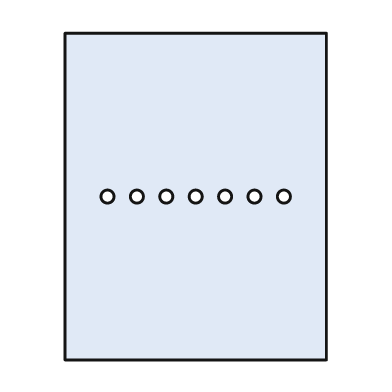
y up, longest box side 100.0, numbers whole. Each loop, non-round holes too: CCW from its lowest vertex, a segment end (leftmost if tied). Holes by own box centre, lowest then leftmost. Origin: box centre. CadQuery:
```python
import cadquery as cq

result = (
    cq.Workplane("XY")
    .moveTo(-40.0, -50.0)
    .lineTo(40.0, -50.0)
    .lineTo(40.0, 50.0)
    .lineTo(-40.0, 50.0)
    .close()
    .moveTo(-27.0, 0.0)
    .circle(2.0)
    .moveTo(-18.0, 0.0)
    .circle(2.0)
    .moveTo(-9.0, 0.0)
    .circle(2.0)
    .moveTo(0.0, 0.0)
    .circle(2.0)
    .moveTo(9.0, 0.0)
    .circle(2.0)
    .moveTo(18.0, 0.0)
    .circle(2.0)
    .moveTo(27.0, 0.0)
    .circle(2.0)
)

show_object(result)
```